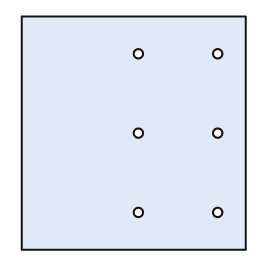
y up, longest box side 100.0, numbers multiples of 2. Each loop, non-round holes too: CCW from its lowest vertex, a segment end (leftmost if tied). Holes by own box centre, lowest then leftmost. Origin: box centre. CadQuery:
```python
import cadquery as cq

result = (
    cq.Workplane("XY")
    .moveTo(-48.0, -50.0)
    .lineTo(48.0, -50.0)
    .lineTo(48.0, 50.0)
    .lineTo(-48.0, 50.0)
    .close()
    .moveTo(2.0, -34.0)
    .circle(2.0)
    .moveTo(36.0, -34.0)
    .circle(2.0)
    .moveTo(2.0, 0.0)
    .circle(2.0)
    .moveTo(36.0, 0.0)
    .circle(2.0)
    .moveTo(2.0, 34.0)
    .circle(2.0)
    .moveTo(36.0, 34.0)
    .circle(2.0)
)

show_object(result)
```